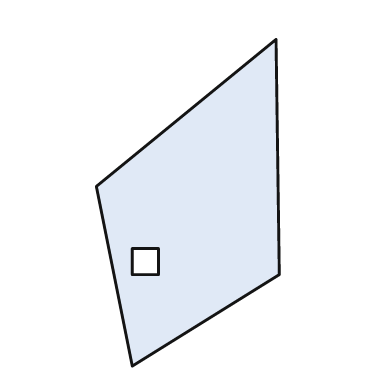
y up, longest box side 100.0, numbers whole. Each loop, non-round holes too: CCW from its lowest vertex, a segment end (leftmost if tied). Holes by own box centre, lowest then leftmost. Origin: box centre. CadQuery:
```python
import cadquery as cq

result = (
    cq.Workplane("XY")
    .moveTo(-17.0, -50.0)
    .lineTo(28.0, -22.0)
    .lineTo(27.0, 50.0)
    .lineTo(-28.0, 5.0)
    .close()
    .moveTo(-17.0, -22.0)
    .lineTo(-9.0, -22.0)
    .lineTo(-9.0, -14.0)
    .lineTo(-17.0, -14.0)
    .close()
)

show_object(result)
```